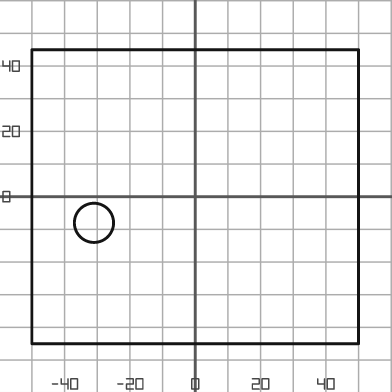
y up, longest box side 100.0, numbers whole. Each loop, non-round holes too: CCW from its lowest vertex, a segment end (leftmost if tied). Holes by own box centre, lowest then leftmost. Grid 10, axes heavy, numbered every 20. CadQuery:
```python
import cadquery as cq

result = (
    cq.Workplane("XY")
    .moveTo(-50.0, -45.0)
    .lineTo(50.0, -45.0)
    .lineTo(50.0, 45.0)
    .lineTo(-50.0, 45.0)
    .close()
    .moveTo(-31.0, -8.0)
    .circle(6.0)
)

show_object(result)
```